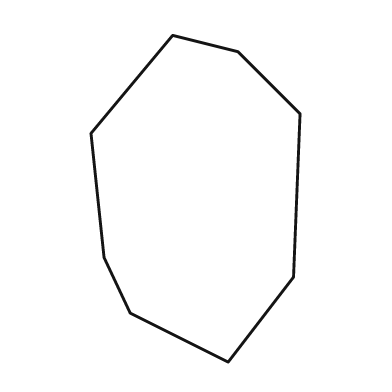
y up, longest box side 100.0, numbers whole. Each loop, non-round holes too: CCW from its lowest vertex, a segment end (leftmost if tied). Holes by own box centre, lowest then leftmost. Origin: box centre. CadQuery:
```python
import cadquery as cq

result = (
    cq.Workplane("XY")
    .moveTo(10.0, -50.0)
    .lineTo(30.0, -24.0)
    .lineTo(32.0, 26.0)
    .lineTo(13.0, 45.0)
    .lineTo(-7.0, 50.0)
    .lineTo(-32.0, 20.0)
    .lineTo(-28.0, -18.0)
    .lineTo(-20.0, -35.0)
    .close()
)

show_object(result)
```